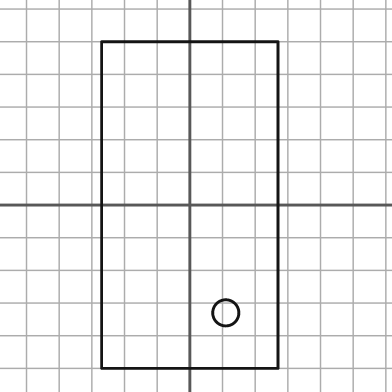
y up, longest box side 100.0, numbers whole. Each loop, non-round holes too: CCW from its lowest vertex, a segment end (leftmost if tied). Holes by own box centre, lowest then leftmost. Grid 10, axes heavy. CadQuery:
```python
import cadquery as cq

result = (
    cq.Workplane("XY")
    .moveTo(-27.0, -50.0)
    .lineTo(27.0, -50.0)
    .lineTo(27.0, 50.0)
    .lineTo(-27.0, 50.0)
    .close()
    .moveTo(11.0, -33.0)
    .circle(4.0)
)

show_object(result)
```